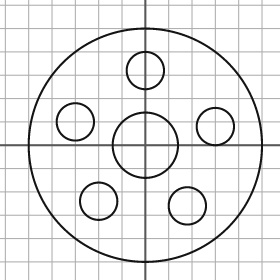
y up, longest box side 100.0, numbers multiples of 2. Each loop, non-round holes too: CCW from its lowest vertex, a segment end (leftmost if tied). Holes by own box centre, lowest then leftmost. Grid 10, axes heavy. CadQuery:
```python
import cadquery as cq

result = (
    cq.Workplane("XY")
    .moveTo(0.0, 0.0)
    .circle(50.0)
    .moveTo(18.0, -26.0)
    .circle(8.0)
    .moveTo(-20.0, -24.0)
    .circle(8.0)
    .moveTo(0.0, 0.0)
    .circle(14.0)
    .moveTo(30.0, 8.0)
    .circle(8.0)
    .moveTo(-30.0, 10.0)
    .circle(8.0)
    .moveTo(0.0, 32.0)
    .circle(8.0)
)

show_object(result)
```